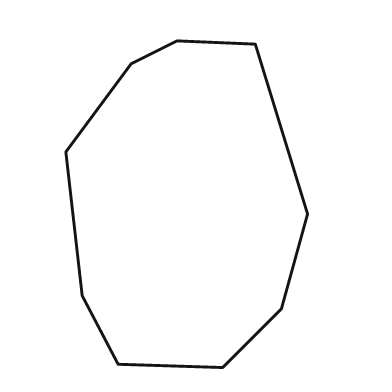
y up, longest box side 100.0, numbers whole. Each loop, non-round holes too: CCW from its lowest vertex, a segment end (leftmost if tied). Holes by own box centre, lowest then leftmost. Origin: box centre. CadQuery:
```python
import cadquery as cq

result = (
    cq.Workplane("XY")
    .moveTo(11.0, -50.0)
    .lineTo(29.0, -32.0)
    .lineTo(37.0, -3.0)
    .lineTo(21.0, 49.0)
    .lineTo(-3.0, 50.0)
    .lineTo(-17.0, 43.0)
    .lineTo(-37.0, 16.0)
    .lineTo(-32.0, -28.0)
    .lineTo(-21.0, -49.0)
    .close()
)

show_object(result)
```